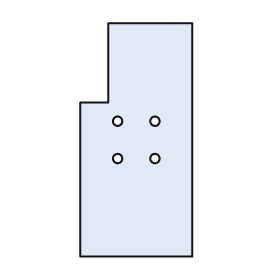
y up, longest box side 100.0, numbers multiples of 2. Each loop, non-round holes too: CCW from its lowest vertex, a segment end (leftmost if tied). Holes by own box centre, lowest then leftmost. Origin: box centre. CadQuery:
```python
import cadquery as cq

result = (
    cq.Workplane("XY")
    .moveTo(-24.0, -50.0)
    .lineTo(24.0, -50.0)
    .lineTo(24.0, 50.0)
    .lineTo(-12.0, 50.0)
    .lineTo(-12.0, 16.0)
    .lineTo(-24.0, 16.0)
    .close()
    .moveTo(-8.0, -8.0)
    .circle(2.0)
    .moveTo(8.0, -8.0)
    .circle(2.0)
    .moveTo(-8.0, 8.0)
    .circle(2.0)
    .moveTo(8.0, 8.0)
    .circle(2.0)
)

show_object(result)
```